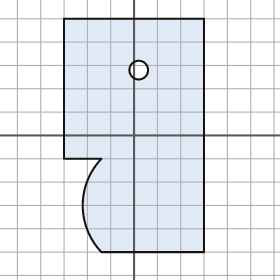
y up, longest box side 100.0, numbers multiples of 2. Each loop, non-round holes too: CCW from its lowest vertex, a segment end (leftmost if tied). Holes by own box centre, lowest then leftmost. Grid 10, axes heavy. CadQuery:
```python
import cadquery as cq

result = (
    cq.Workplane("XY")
    .moveTo(-14.0, -50.0)
    .lineTo(30.0, -50.0)
    .lineTo(30.0, 50.0)
    .lineTo(-30.0, 50.0)
    .lineTo(-30.0, -10.0)
    .lineTo(-14.0, -10.0)
    .threePointArc((-22.0, -30.0), (-14.0, -50.0))
    .close()
    .moveTo(2.0, 28.0)
    .circle(4.0)
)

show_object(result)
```